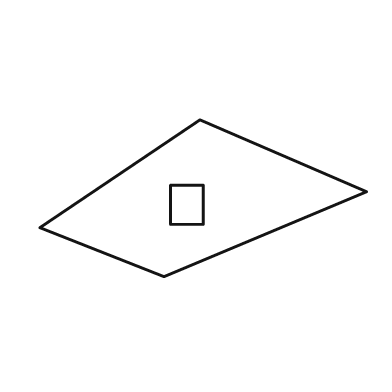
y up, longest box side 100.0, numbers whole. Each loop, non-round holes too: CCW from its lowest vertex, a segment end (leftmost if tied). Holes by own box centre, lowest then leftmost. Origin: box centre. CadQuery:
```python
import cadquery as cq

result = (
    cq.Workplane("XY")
    .moveTo(-12.0, -24.0)
    .lineTo(50.0, 2.0)
    .lineTo(-1.0, 24.0)
    .lineTo(-50.0, -9.0)
    .close()
    .moveTo(-10.0, -8.0)
    .lineTo(0.0, -8.0)
    .lineTo(0.0, 4.0)
    .lineTo(-10.0, 4.0)
    .close()
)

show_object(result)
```